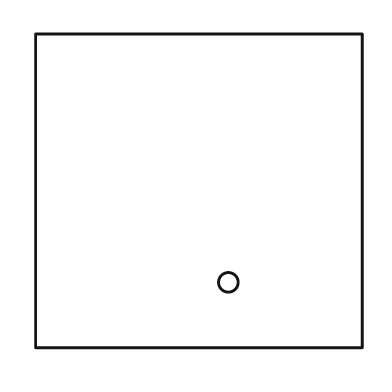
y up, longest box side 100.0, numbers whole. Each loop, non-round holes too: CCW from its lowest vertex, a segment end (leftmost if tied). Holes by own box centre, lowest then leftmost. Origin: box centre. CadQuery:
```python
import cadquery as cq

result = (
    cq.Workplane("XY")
    .moveTo(-50.0, -48.0)
    .lineTo(50.0, -48.0)
    .lineTo(50.0, 48.0)
    .lineTo(-50.0, 48.0)
    .close()
    .moveTo(9.0, -28.0)
    .circle(3.0)
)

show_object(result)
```